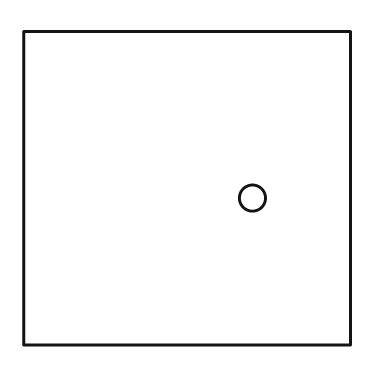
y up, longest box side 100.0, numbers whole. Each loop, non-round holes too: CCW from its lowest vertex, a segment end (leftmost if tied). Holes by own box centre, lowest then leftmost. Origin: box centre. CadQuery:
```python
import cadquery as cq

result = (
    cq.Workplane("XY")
    .moveTo(-50.0, -48.0)
    .lineTo(50.0, -48.0)
    .lineTo(50.0, 48.0)
    .lineTo(-50.0, 48.0)
    .close()
    .moveTo(20.0, -3.0)
    .circle(4.0)
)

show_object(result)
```